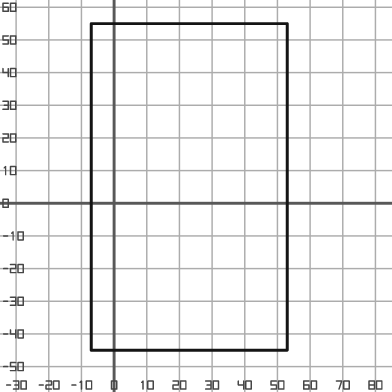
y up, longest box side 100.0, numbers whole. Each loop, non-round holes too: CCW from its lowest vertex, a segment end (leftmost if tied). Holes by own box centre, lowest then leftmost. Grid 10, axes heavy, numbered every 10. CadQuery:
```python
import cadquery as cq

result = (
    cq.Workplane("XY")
    .moveTo(-7.0, -45.0)
    .lineTo(53.0, -45.0)
    .lineTo(53.0, 55.0)
    .lineTo(-7.0, 55.0)
    .close()
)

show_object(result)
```